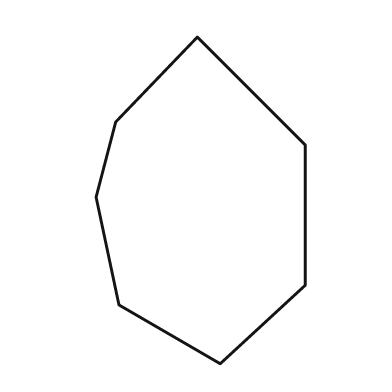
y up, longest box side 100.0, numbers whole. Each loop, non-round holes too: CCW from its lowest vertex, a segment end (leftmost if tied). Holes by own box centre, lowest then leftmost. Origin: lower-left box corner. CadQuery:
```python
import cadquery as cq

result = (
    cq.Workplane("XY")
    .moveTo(38.0, 0.0)
    .lineTo(64.0, 24.0)
    .lineTo(64.0, 67.0)
    .lineTo(31.0, 100.0)
    .lineTo(6.0, 74.0)
    .lineTo(0.0, 51.0)
    .lineTo(7.0, 18.0)
    .close()
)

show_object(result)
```